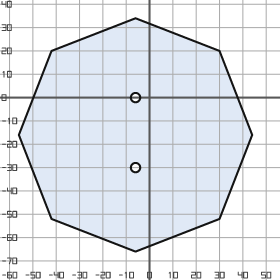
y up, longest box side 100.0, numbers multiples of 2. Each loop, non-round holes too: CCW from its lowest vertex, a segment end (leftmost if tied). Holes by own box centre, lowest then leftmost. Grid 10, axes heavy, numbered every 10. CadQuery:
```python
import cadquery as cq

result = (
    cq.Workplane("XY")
    .moveTo(-6.0, -66.0)
    .lineTo(30.0, -52.0)
    .lineTo(44.0, -16.0)
    .lineTo(30.0, 20.0)
    .lineTo(-6.0, 34.0)
    .lineTo(-42.0, 20.0)
    .lineTo(-56.0, -16.0)
    .lineTo(-42.0, -52.0)
    .close()
    .moveTo(-6.0, -30.0)
    .circle(2.0)
    .moveTo(-6.0, 0.0)
    .circle(2.0)
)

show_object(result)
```